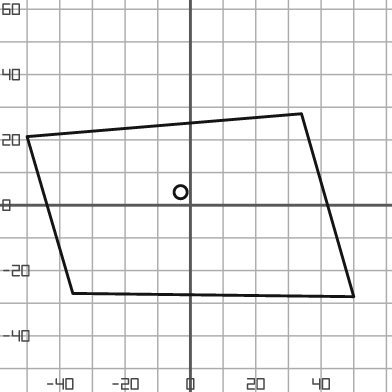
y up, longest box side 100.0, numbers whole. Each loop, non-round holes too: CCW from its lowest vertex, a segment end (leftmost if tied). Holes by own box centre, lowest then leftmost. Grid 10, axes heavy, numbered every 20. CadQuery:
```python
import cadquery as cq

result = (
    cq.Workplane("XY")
    .moveTo(50.0, -28.0)
    .lineTo(34.0, 28.0)
    .lineTo(-50.0, 21.0)
    .lineTo(-36.0, -27.0)
    .close()
    .moveTo(-3.0, 4.0)
    .circle(2.0)
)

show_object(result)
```